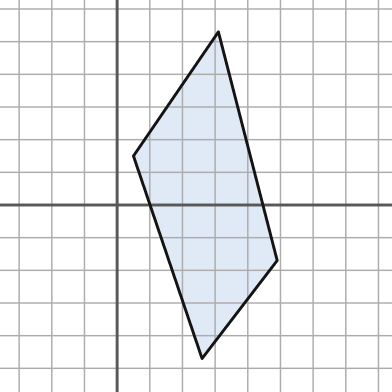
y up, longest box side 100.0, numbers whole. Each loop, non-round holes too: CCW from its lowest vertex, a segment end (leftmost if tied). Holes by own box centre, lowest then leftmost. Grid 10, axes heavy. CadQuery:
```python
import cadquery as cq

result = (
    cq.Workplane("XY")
    .moveTo(26.0, -47.0)
    .lineTo(49.0, -17.0)
    .lineTo(31.0, 53.0)
    .lineTo(5.0, 15.0)
    .close()
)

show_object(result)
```